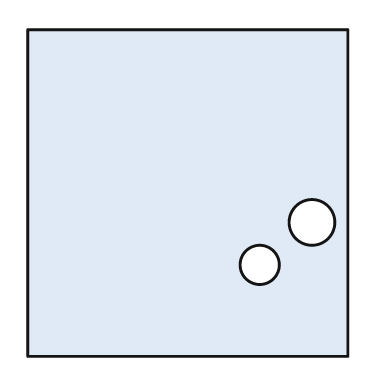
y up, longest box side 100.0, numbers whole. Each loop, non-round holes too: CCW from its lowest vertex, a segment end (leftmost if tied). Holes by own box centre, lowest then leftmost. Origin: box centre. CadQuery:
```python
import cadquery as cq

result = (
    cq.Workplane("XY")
    .moveTo(-49.0, -50.0)
    .lineTo(49.0, -50.0)
    .lineTo(49.0, 50.0)
    .lineTo(-49.0, 50.0)
    .close()
    .moveTo(22.0, -22.0)
    .circle(6.0)
    .moveTo(38.0, -9.0)
    .circle(7.0)
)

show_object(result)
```